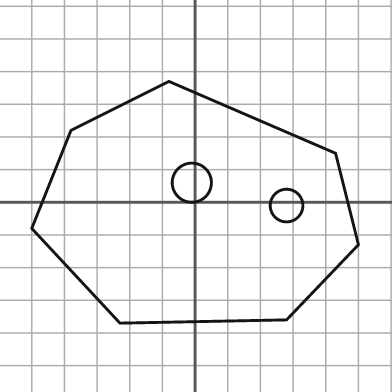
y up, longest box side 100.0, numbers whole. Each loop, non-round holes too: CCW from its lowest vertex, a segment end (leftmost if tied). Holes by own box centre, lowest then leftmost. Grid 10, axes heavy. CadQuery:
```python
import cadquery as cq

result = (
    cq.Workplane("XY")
    .moveTo(-23.0, -37.0)
    .lineTo(28.0, -36.0)
    .lineTo(50.0, -13.0)
    .lineTo(43.0, 15.0)
    .lineTo(-8.0, 37.0)
    .lineTo(-38.0, 22.0)
    .lineTo(-50.0, -8.0)
    .close()
    .moveTo(28.0, -1.0)
    .circle(5.0)
    .moveTo(-1.0, 6.0)
    .circle(6.0)
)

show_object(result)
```